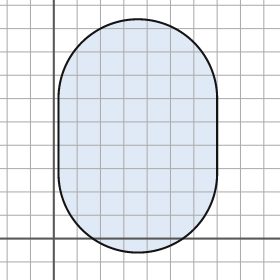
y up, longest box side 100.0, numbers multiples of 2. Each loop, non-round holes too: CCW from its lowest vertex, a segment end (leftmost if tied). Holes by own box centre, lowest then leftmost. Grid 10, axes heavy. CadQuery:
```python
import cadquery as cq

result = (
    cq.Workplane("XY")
    .moveTo(2.0, 28.0)
    .threePointArc((36.0, -6.0), (70.0, 28.0))
    .lineTo(70.0, 60.0)
    .threePointArc((36.0, 94.0), (2.0, 60.0))
    .close()
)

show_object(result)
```